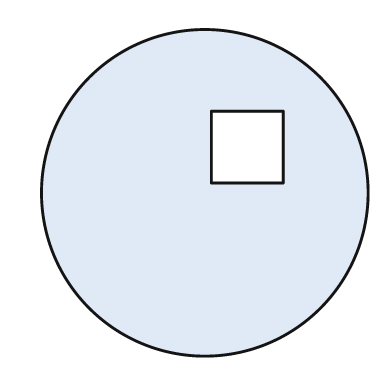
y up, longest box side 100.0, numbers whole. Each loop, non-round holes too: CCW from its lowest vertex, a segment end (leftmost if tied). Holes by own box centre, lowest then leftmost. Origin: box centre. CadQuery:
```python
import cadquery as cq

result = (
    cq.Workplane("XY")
    .moveTo(0.0, 0.0)
    .circle(50.0)
    .moveTo(2.0, 3.0)
    .lineTo(24.0, 3.0)
    .lineTo(24.0, 25.0)
    .lineTo(2.0, 25.0)
    .close()
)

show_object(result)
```